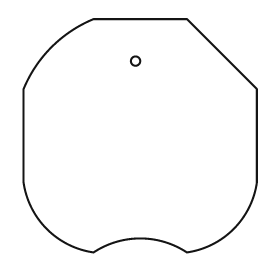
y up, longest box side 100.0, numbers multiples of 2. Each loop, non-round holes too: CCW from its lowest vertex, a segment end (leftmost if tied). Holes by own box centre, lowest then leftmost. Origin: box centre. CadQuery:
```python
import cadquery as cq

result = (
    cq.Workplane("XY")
    .moveTo(-20.0, -50.0)
    .threePointArc((0.0, -44.0), (20.0, -50.0))
    .threePointArc((40.0, -40.0), (50.0, -20.0))
    .lineTo(50.0, 20.0)
    .lineTo(20.0, 50.0)
    .lineTo(-20.0, 50.0)
    .threePointArc((-38.0, 38.0), (-50.0, 20.0))
    .lineTo(-50.0, -20.0)
    .threePointArc((-40.0, -40.0), (-20.0, -50.0))
    .close()
    .moveTo(-2.0, 32.0)
    .circle(2.0)
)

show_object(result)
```